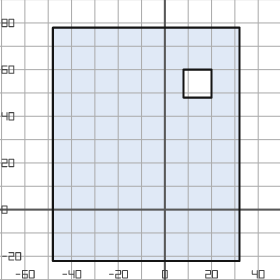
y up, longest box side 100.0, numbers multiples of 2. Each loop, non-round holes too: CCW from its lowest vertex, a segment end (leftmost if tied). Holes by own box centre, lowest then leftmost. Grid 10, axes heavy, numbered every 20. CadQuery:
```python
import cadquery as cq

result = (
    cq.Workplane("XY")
    .moveTo(-48.0, -22.0)
    .lineTo(32.0, -22.0)
    .lineTo(32.0, 78.0)
    .lineTo(-48.0, 78.0)
    .close()
    .moveTo(8.0, 48.0)
    .lineTo(20.0, 48.0)
    .lineTo(20.0, 60.0)
    .lineTo(8.0, 60.0)
    .close()
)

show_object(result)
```